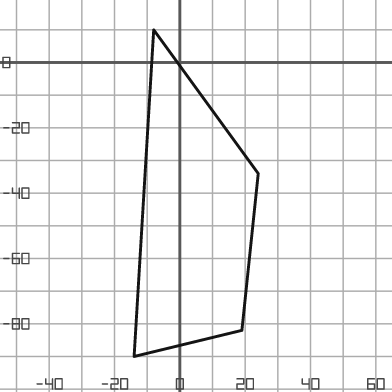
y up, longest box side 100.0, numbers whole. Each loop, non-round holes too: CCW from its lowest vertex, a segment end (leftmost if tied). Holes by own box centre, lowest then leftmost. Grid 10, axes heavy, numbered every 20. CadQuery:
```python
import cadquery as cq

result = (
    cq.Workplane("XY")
    .moveTo(-14.0, -90.0)
    .lineTo(19.0, -82.0)
    .lineTo(24.0, -34.0)
    .lineTo(-8.0, 10.0)
    .close()
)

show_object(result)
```